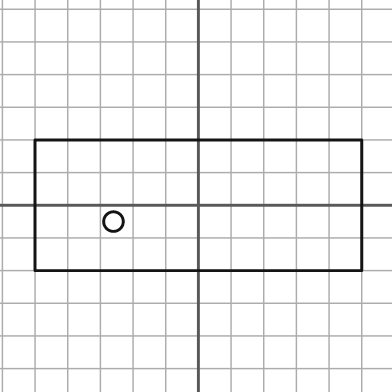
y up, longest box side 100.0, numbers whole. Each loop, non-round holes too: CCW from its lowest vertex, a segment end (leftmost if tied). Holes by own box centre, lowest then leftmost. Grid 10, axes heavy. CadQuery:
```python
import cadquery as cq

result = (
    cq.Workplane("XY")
    .moveTo(-50.0, -20.0)
    .lineTo(50.0, -20.0)
    .lineTo(50.0, 20.0)
    .lineTo(-50.0, 20.0)
    .close()
    .moveTo(-26.0, -5.0)
    .circle(3.0)
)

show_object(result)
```